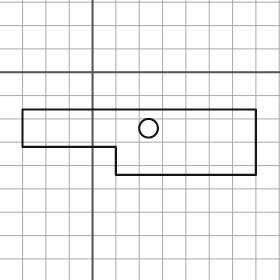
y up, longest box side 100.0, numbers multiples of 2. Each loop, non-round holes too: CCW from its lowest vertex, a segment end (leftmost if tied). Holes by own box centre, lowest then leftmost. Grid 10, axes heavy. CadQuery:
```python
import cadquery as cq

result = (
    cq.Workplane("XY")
    .moveTo(10.0, -44.0)
    .lineTo(70.0, -44.0)
    .lineTo(70.0, -16.0)
    .lineTo(-30.0, -16.0)
    .lineTo(-30.0, -32.0)
    .lineTo(10.0, -32.0)
    .close()
    .moveTo(24.0, -24.0)
    .circle(4.0)
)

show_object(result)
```